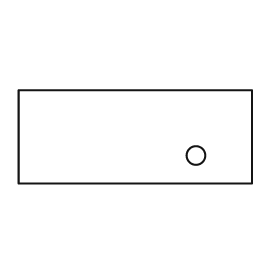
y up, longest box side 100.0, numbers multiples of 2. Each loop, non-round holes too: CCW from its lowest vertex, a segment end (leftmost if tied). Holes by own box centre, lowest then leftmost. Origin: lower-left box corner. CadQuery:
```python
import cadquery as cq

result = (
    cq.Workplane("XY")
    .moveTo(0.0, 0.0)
    .lineTo(100.0, 0.0)
    .lineTo(100.0, 40.0)
    .lineTo(0.0, 40.0)
    .close()
    .moveTo(76.0, 12.0)
    .circle(4.0)
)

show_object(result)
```